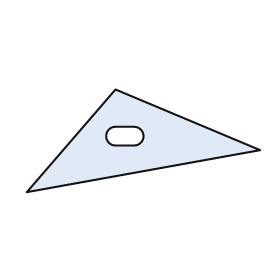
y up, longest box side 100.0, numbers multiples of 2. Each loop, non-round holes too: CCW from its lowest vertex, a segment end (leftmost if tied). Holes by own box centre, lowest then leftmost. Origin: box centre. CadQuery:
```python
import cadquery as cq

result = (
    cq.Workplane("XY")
    .moveTo(-50.0, -22.0)
    .lineTo(50.0, -4.0)
    .lineTo(-12.0, 22.0)
    .close()
    .moveTo(-12.0, -2.0)
    .lineTo(-4.0, -2.0)
    .threePointArc((0.0, 2.0), (-4.0, 6.0))
    .lineTo(-12.0, 6.0)
    .threePointArc((-16.0, 2.0), (-12.0, -2.0))
    .close()
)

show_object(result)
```